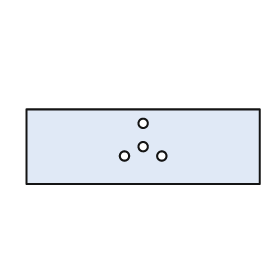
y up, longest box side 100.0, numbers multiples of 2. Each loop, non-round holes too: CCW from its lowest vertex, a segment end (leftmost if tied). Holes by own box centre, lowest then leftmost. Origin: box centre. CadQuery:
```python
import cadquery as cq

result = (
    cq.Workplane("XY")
    .moveTo(-50.0, -16.0)
    .lineTo(50.0, -16.0)
    .lineTo(50.0, 16.0)
    .lineTo(-50.0, 16.0)
    .close()
    .moveTo(-8.0, -4.0)
    .circle(2.0)
    .moveTo(8.0, -4.0)
    .circle(2.0)
    .moveTo(0.0, 0.0)
    .circle(2.0)
    .moveTo(0.0, 10.0)
    .circle(2.0)
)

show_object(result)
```